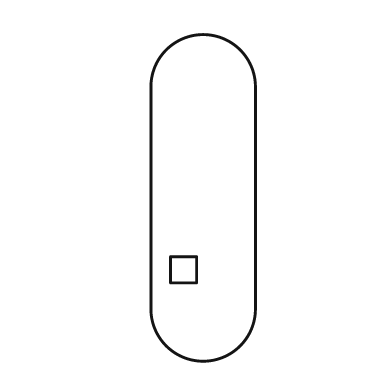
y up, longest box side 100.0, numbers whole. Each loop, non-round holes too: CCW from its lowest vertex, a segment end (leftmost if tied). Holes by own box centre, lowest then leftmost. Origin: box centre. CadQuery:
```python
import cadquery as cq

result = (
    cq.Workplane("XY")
    .moveTo(-16.0, -34.0)
    .threePointArc((0.0, -50.0), (16.0, -34.0))
    .lineTo(16.0, 34.0)
    .threePointArc((0.0, 50.0), (-16.0, 34.0))
    .close()
    .moveTo(-10.0, -26.0)
    .lineTo(-2.0, -26.0)
    .lineTo(-2.0, -18.0)
    .lineTo(-10.0, -18.0)
    .close()
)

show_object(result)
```